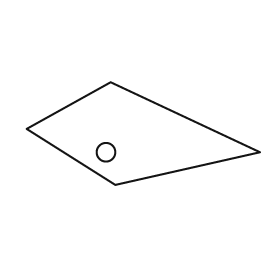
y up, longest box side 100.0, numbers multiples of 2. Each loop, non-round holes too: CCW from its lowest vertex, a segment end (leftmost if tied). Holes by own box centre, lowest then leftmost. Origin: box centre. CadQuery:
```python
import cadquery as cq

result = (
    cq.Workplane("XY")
    .moveTo(-12.0, -22.0)
    .lineTo(50.0, -8.0)
    .lineTo(-14.0, 22.0)
    .lineTo(-50.0, 2.0)
    .close()
    .moveTo(-16.0, -8.0)
    .circle(4.0)
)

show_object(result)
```